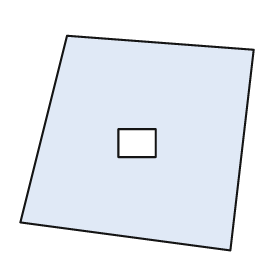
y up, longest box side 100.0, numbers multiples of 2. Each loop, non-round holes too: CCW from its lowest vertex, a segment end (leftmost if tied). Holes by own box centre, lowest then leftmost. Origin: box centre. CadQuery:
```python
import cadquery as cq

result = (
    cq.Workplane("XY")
    .moveTo(40.0, -46.0)
    .lineTo(50.0, 40.0)
    .lineTo(-30.0, 46.0)
    .lineTo(-50.0, -34.0)
    .close()
    .moveTo(-8.0, -6.0)
    .lineTo(8.0, -6.0)
    .lineTo(8.0, 6.0)
    .lineTo(-8.0, 6.0)
    .close()
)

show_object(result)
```